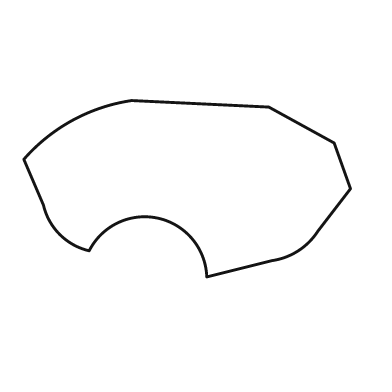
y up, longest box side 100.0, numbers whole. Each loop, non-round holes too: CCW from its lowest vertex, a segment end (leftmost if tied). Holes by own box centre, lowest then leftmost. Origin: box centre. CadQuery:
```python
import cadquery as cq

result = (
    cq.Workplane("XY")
    .moveTo(6.0, -27.0)
    .lineTo(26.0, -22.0)
    .threePointArc((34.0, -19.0), (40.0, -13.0))
    .lineTo(50.0, 0.0)
    .lineTo(45.0, 14.0)
    .lineTo(25.0, 25.0)
    .lineTo(-17.0, 27.0)
    .threePointArc((-35.0, 21.0), (-50.0, 9.0))
    .lineTo(-44.0, -5.0)
    .threePointArc((-39.0, -14.0), (-30.0, -19.0))
    .threePointArc((-9.0, -9.0), (6.0, -27.0))
    .close()
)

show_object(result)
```